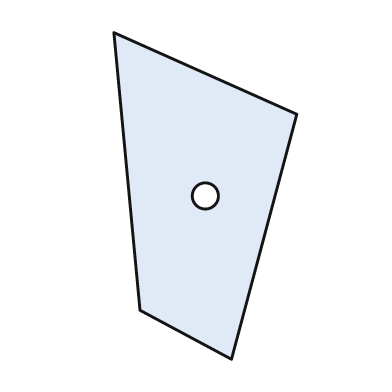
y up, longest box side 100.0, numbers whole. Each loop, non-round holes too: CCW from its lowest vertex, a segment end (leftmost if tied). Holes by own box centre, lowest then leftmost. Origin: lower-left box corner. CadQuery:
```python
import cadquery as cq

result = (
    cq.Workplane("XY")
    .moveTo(36.0, 0.0)
    .lineTo(56.0, 75.0)
    .lineTo(0.0, 100.0)
    .lineTo(8.0, 15.0)
    .close()
    .moveTo(28.0, 50.0)
    .circle(4.0)
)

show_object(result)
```